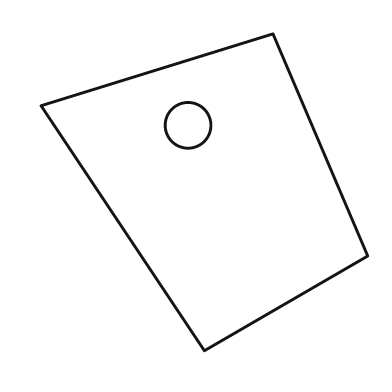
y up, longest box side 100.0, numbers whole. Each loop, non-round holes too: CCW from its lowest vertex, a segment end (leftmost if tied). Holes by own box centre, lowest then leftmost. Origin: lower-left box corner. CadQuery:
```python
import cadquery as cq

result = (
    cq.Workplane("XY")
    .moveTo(50.0, 0.0)
    .lineTo(100.0, 29.0)
    .lineTo(71.0, 97.0)
    .lineTo(0.0, 75.0)
    .close()
    .moveTo(45.0, 69.0)
    .circle(7.0)
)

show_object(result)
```